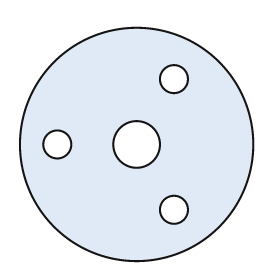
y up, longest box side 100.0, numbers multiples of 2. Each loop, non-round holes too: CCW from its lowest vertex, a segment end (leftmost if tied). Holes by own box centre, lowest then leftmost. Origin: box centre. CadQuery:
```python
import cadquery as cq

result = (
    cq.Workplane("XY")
    .moveTo(0.0, 0.0)
    .circle(50.0)
    .moveTo(16.0, -28.0)
    .circle(6.0)
    .moveTo(-34.0, 0.0)
    .circle(6.0)
    .moveTo(0.0, 0.0)
    .circle(10.0)
    .moveTo(16.0, 28.0)
    .circle(6.0)
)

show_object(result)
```